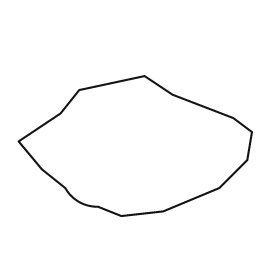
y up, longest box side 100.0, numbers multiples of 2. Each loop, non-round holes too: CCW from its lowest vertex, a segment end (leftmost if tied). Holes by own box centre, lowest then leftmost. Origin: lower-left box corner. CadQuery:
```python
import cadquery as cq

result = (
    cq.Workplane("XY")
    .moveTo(44.0, 0.0)
    .lineTo(62.0, 2.0)
    .lineTo(86.0, 12.0)
    .lineTo(98.0, 24.0)
    .lineTo(100.0, 36.0)
    .lineTo(92.0, 42.0)
    .lineTo(66.0, 52.0)
    .lineTo(54.0, 60.0)
    .lineTo(26.0, 54.0)
    .lineTo(18.0, 44.0)
    .lineTo(0.0, 32.0)
    .lineTo(10.0, 20.0)
    .lineTo(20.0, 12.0)
    .threePointArc((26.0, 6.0), (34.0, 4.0))
    .close()
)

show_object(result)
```